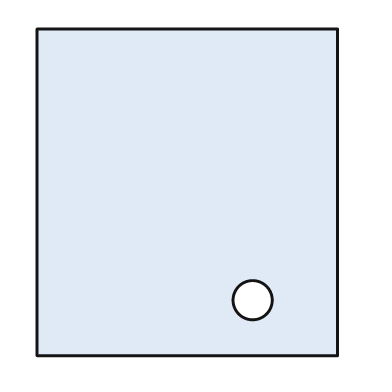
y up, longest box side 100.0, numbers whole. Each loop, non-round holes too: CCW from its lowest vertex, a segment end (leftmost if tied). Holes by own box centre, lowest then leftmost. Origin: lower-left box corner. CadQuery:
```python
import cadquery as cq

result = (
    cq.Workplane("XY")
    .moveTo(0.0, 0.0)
    .lineTo(92.0, 0.0)
    .lineTo(92.0, 100.0)
    .lineTo(0.0, 100.0)
    .close()
    .moveTo(66.0, 17.0)
    .circle(6.0)
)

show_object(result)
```